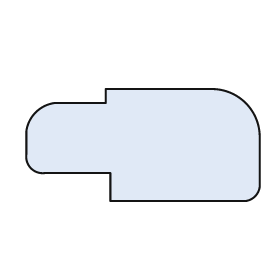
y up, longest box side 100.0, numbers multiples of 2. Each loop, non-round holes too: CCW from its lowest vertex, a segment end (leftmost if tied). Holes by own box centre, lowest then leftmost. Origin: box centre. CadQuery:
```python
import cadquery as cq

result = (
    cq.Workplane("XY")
    .moveTo(-14.0, -24.0)
    .lineTo(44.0, -24.0)
    .threePointArc((48.0, -22.0), (50.0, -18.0))
    .lineTo(50.0, 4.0)
    .threePointArc((44.0, 18.0), (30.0, 24.0))
    .lineTo(-16.0, 24.0)
    .lineTo(-16.0, 18.0)
    .lineTo(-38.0, 18.0)
    .threePointArc((-46.0, 14.0), (-50.0, 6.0))
    .lineTo(-50.0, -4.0)
    .threePointArc((-48.0, -10.0), (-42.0, -12.0))
    .lineTo(-14.0, -12.0)
    .close()
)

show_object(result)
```